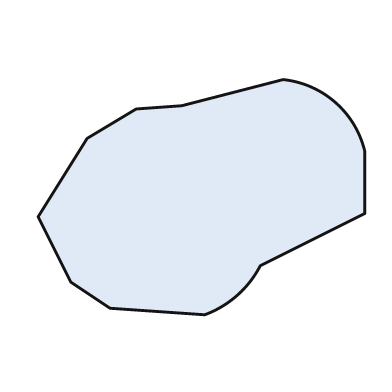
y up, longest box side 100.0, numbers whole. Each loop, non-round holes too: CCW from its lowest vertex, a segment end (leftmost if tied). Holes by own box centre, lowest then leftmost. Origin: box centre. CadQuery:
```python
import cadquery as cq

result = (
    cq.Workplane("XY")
    .moveTo(1.0, -36.0)
    .threePointArc((11.0, -30.0), (18.0, -21.0))
    .lineTo(50.0, -5.0)
    .lineTo(50.0, 14.0)
    .threePointArc((41.0, 29.0), (25.0, 36.0))
    .lineTo(-6.0, 28.0)
    .lineTo(-20.0, 27.0)
    .lineTo(-35.0, 18.0)
    .lineTo(-50.0, -6.0)
    .lineTo(-40.0, -26.0)
    .lineTo(-28.0, -34.0)
    .close()
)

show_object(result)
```